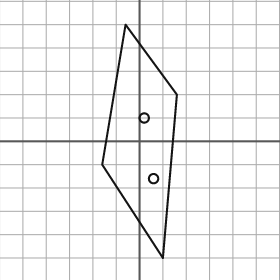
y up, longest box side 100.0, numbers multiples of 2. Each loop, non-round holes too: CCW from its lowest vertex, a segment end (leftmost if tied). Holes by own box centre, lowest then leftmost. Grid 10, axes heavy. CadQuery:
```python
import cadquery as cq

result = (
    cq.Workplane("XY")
    .moveTo(10.0, -50.0)
    .lineTo(16.0, 20.0)
    .lineTo(-6.0, 50.0)
    .lineTo(-16.0, -10.0)
    .close()
    .moveTo(6.0, -16.0)
    .circle(2.0)
    .moveTo(2.0, 10.0)
    .circle(2.0)
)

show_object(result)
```